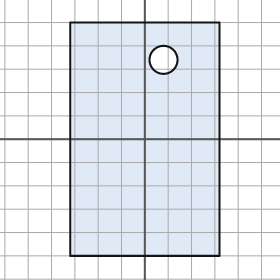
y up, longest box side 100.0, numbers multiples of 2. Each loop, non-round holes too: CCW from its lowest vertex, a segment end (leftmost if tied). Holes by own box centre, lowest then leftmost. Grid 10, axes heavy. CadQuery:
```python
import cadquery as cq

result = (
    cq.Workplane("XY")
    .moveTo(-32.0, -50.0)
    .lineTo(32.0, -50.0)
    .lineTo(32.0, 50.0)
    .lineTo(-32.0, 50.0)
    .close()
    .moveTo(8.0, 34.0)
    .circle(6.0)
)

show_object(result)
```